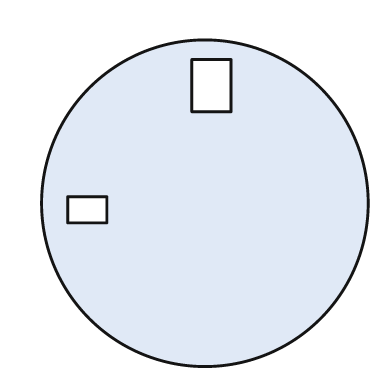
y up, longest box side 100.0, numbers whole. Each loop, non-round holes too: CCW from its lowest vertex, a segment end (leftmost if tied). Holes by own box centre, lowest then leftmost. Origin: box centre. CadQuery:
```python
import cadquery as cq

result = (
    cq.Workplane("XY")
    .moveTo(0.0, 0.0)
    .circle(50.0)
    .moveTo(-42.0, -6.0)
    .lineTo(-30.0, -6.0)
    .lineTo(-30.0, 2.0)
    .lineTo(-42.0, 2.0)
    .close()
    .moveTo(-4.0, 28.0)
    .lineTo(8.0, 28.0)
    .lineTo(8.0, 44.0)
    .lineTo(-4.0, 44.0)
    .close()
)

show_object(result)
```